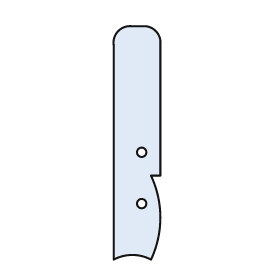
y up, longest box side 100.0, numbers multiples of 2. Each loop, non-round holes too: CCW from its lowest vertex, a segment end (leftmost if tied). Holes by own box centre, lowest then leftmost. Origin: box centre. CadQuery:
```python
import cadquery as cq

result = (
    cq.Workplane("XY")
    .moveTo(-10.0, -50.0)
    .threePointArc((-2.0, -48.0), (6.0, -50.0))
    .threePointArc((10.0, -32.0), (6.0, -14.0))
    .lineTo(10.0, -14.0)
    .lineTo(10.0, 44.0)
    .threePointArc((8.0, 48.0), (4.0, 50.0))
    .lineTo(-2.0, 50.0)
    .threePointArc((-8.0, 48.0), (-10.0, 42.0))
    .close()
    .moveTo(2.0, -26.0)
    .circle(2.0)
    .moveTo(2.0, -4.0)
    .circle(2.0)
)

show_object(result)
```